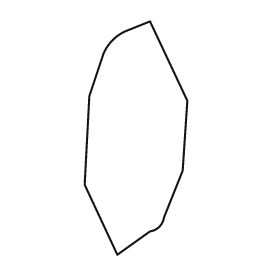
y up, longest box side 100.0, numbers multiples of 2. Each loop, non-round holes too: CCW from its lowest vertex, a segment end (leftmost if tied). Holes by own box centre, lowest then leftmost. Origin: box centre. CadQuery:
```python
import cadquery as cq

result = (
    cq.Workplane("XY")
    .moveTo(-8.0, -50.0)
    .lineTo(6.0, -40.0)
    .threePointArc((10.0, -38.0), (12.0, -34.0))
    .lineTo(20.0, -14.0)
    .lineTo(22.0, 16.0)
    .lineTo(6.0, 50.0)
    .lineTo(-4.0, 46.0)
    .threePointArc((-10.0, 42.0), (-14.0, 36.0))
    .lineTo(-20.0, 18.0)
    .lineTo(-22.0, -20.0)
    .close()
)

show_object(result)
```